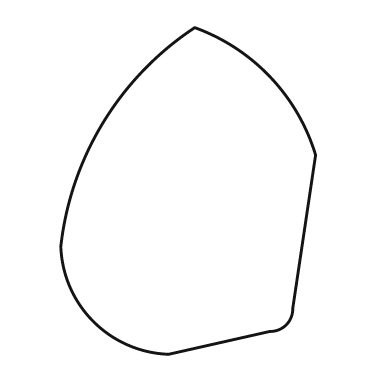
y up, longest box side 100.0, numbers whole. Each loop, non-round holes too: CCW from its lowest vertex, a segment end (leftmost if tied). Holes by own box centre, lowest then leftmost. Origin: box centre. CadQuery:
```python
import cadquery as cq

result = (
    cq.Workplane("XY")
    .moveTo(-6.0, -50.0)
    .lineTo(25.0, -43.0)
    .threePointArc((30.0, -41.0), (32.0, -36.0))
    .lineTo(39.0, 11.0)
    .threePointArc((25.0, 35.0), (2.0, 50.0))
    .threePointArc((-26.0, 21.0), (-39.0, -17.0))
    .threePointArc((-29.0, -40.0), (-6.0, -50.0))
    .close()
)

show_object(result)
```